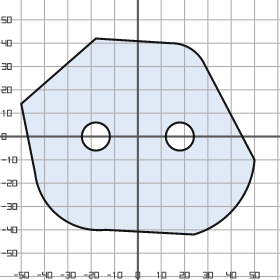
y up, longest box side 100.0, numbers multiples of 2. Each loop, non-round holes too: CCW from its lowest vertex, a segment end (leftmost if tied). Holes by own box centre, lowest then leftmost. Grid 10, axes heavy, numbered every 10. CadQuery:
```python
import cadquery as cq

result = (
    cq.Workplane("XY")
    .moveTo(24.0, -42.0)
    .threePointArc((42.0, -30.0), (50.0, -10.0))
    .lineTo(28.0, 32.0)
    .threePointArc((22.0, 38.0), (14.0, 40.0))
    .lineTo(-18.0, 42.0)
    .lineTo(-50.0, 14.0)
    .lineTo(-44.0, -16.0)
    .threePointArc((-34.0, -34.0), (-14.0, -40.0))
    .close()
    .moveTo(-18.0, 0.0)
    .circle(6.0)
    .moveTo(18.0, 0.0)
    .circle(6.0)
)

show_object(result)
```